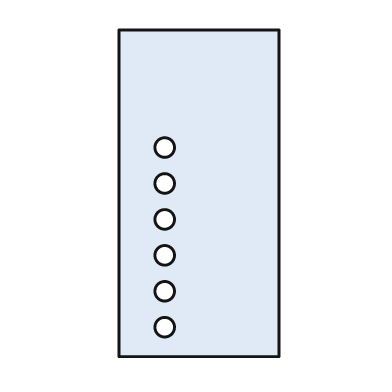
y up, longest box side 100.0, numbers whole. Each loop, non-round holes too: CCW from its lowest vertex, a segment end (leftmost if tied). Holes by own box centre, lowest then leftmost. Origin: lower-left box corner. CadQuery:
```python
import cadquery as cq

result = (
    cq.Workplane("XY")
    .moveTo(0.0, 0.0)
    .lineTo(49.0, 0.0)
    .lineTo(49.0, 100.0)
    .lineTo(0.0, 100.0)
    .close()
    .moveTo(14.0, 9.0)
    .circle(3.0)
    .moveTo(14.0, 20.0)
    .circle(3.0)
    .moveTo(14.0, 31.0)
    .circle(3.0)
    .moveTo(14.0, 42.0)
    .circle(3.0)
    .moveTo(14.0, 53.0)
    .circle(3.0)
    .moveTo(14.0, 64.0)
    .circle(3.0)
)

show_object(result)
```